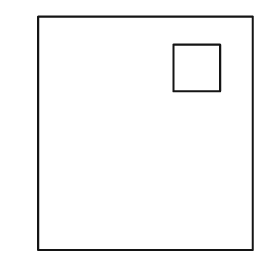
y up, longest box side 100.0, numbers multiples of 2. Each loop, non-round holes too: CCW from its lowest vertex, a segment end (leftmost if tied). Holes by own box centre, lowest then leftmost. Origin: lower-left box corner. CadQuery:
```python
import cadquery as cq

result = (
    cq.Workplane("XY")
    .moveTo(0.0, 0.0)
    .lineTo(92.0, 0.0)
    .lineTo(92.0, 100.0)
    .lineTo(0.0, 100.0)
    .close()
    .moveTo(58.0, 68.0)
    .lineTo(78.0, 68.0)
    .lineTo(78.0, 88.0)
    .lineTo(58.0, 88.0)
    .close()
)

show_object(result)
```